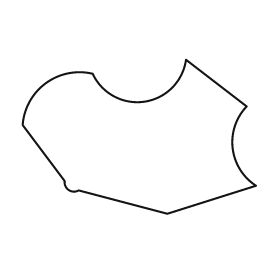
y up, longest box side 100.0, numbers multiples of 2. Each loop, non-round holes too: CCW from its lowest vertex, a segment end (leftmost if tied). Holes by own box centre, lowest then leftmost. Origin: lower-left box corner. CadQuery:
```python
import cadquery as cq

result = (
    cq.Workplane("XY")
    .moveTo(62.0, 0.0)
    .lineTo(100.0, 12.0)
    .threePointArc((90.0, 28.0), (96.0, 46.0))
    .lineTo(70.0, 66.0)
    .threePointArc((52.0, 48.0), (30.0, 60.0))
    .threePointArc((10.0, 56.0), (0.0, 38.0))
    .lineTo(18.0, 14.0)
    .threePointArc((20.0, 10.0), (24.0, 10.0))
    .close()
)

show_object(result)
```